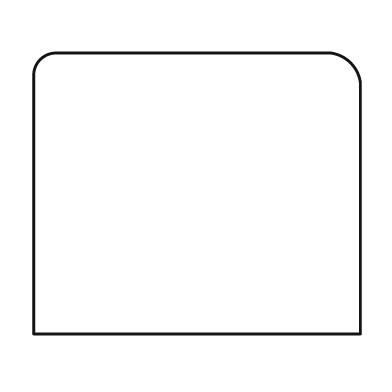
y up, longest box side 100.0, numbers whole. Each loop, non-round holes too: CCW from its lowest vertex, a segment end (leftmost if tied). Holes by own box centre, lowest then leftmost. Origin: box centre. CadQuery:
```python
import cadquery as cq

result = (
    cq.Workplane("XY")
    .moveTo(-50.0, -43.0)
    .lineTo(50.0, -43.0)
    .lineTo(50.0, 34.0)
    .threePointArc((47.0, 40.0), (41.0, 43.0))
    .lineTo(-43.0, 43.0)
    .threePointArc((-48.0, 41.0), (-50.0, 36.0))
    .close()
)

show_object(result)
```